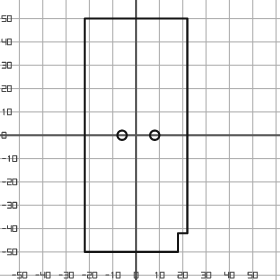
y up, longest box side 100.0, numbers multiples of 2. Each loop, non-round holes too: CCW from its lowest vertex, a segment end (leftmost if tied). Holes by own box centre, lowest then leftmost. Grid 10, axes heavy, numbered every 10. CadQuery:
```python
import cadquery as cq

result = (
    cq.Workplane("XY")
    .moveTo(-22.0, -50.0)
    .lineTo(18.0, -50.0)
    .lineTo(18.0, -42.0)
    .lineTo(22.0, -42.0)
    .lineTo(22.0, 50.0)
    .lineTo(-22.0, 50.0)
    .close()
    .moveTo(-6.0, 0.0)
    .circle(2.0)
    .moveTo(8.0, 0.0)
    .circle(2.0)
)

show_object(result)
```